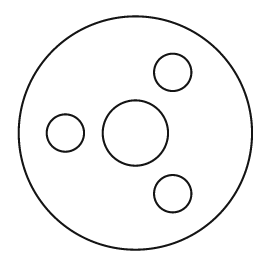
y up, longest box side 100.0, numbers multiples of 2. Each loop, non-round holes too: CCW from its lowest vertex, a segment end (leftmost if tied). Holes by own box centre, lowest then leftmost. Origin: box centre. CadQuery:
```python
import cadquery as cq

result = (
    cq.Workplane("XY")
    .moveTo(0.0, 0.0)
    .circle(50.0)
    .moveTo(16.0, -26.0)
    .circle(8.0)
    .moveTo(-30.0, 0.0)
    .circle(8.0)
    .moveTo(0.0, 0.0)
    .circle(14.0)
    .moveTo(16.0, 26.0)
    .circle(8.0)
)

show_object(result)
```